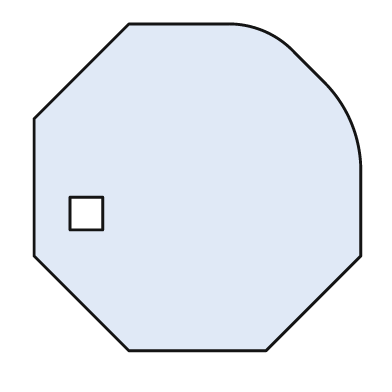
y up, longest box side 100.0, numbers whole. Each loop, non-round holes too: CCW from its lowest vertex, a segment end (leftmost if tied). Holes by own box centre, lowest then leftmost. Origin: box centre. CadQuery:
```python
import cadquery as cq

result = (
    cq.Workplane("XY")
    .moveTo(-21.0, -50.0)
    .lineTo(21.0, -50.0)
    .lineTo(50.0, -21.0)
    .lineTo(50.0, 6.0)
    .threePointArc((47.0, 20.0), (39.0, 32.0))
    .lineTo(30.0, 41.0)
    .threePointArc((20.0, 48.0), (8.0, 50.0))
    .lineTo(-21.0, 50.0)
    .lineTo(-50.0, 21.0)
    .lineTo(-50.0, -21.0)
    .close()
    .moveTo(-39.0, -13.0)
    .lineTo(-29.0, -13.0)
    .lineTo(-29.0, -3.0)
    .lineTo(-39.0, -3.0)
    .close()
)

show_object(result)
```